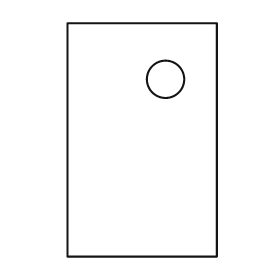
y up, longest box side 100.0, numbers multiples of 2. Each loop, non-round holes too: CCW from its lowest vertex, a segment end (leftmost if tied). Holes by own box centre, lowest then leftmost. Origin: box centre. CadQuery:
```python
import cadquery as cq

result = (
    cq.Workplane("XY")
    .moveTo(-32.0, -50.0)
    .lineTo(32.0, -50.0)
    .lineTo(32.0, 50.0)
    .lineTo(-32.0, 50.0)
    .close()
    .moveTo(10.0, 26.0)
    .circle(8.0)
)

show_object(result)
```